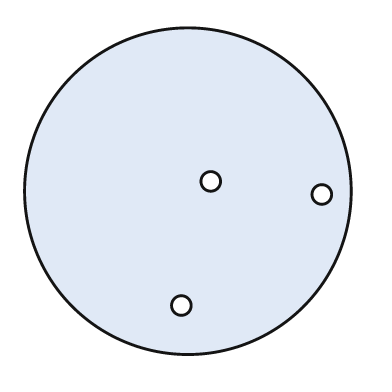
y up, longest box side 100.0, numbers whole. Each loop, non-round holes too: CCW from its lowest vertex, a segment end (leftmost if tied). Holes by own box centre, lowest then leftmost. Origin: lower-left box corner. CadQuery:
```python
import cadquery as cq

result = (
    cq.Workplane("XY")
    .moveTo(50.0, 50.0)
    .circle(50.0)
    .moveTo(48.0, 15.0)
    .circle(3.0)
    .moveTo(91.0, 49.0)
    .circle(3.0)
    .moveTo(57.0, 53.0)
    .circle(3.0)
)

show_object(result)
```